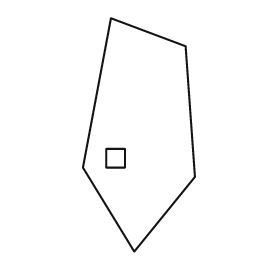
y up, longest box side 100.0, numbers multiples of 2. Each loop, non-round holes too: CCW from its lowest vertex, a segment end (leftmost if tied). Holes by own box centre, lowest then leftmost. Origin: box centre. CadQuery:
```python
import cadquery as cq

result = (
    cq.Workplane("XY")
    .moveTo(-2.0, -50.0)
    .lineTo(24.0, -18.0)
    .lineTo(20.0, 38.0)
    .lineTo(-12.0, 50.0)
    .lineTo(-24.0, -14.0)
    .close()
    .moveTo(-14.0, -14.0)
    .lineTo(-6.0, -14.0)
    .lineTo(-6.0, -6.0)
    .lineTo(-14.0, -6.0)
    .close()
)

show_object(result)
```